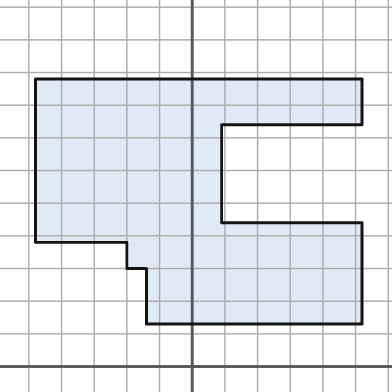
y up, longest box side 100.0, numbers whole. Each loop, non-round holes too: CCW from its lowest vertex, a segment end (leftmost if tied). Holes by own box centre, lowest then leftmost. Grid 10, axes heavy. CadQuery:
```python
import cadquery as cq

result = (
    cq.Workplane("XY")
    .moveTo(-14.0, 13.0)
    .lineTo(52.0, 13.0)
    .lineTo(52.0, 44.0)
    .lineTo(9.0, 44.0)
    .lineTo(9.0, 74.0)
    .lineTo(52.0, 74.0)
    .lineTo(52.0, 88.0)
    .lineTo(-48.0, 88.0)
    .lineTo(-48.0, 38.0)
    .lineTo(-20.0, 38.0)
    .lineTo(-20.0, 30.0)
    .lineTo(-14.0, 30.0)
    .close()
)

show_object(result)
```